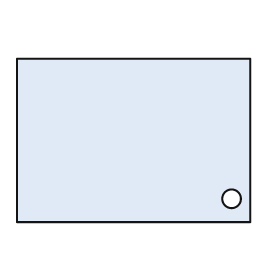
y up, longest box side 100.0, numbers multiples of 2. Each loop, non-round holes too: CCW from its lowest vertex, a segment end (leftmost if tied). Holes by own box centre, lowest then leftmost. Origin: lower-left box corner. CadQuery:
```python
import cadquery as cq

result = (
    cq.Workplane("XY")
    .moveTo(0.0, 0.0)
    .lineTo(100.0, 0.0)
    .lineTo(100.0, 70.0)
    .lineTo(0.0, 70.0)
    .close()
    .moveTo(92.0, 10.0)
    .circle(4.0)
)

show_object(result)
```